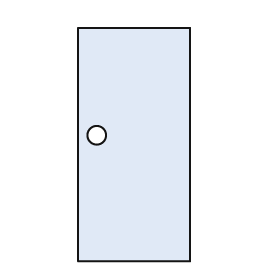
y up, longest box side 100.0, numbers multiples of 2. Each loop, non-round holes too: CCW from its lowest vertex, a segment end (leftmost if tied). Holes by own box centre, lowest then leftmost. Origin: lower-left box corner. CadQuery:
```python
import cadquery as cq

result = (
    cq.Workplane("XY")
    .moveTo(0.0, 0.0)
    .lineTo(48.0, 0.0)
    .lineTo(48.0, 100.0)
    .lineTo(0.0, 100.0)
    .close()
    .moveTo(8.0, 54.0)
    .circle(4.0)
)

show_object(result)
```